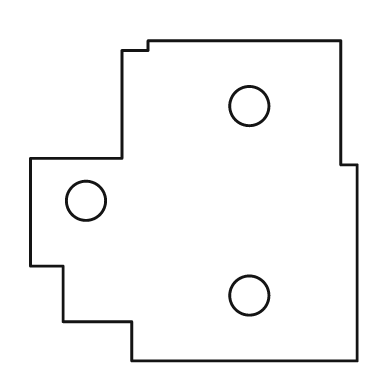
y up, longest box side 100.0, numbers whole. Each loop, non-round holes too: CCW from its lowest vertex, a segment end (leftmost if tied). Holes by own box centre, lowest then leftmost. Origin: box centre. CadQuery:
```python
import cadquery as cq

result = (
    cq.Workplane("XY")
    .moveTo(-19.0, -49.0)
    .lineTo(50.0, -49.0)
    .lineTo(50.0, 11.0)
    .lineTo(45.0, 11.0)
    .lineTo(45.0, 49.0)
    .lineTo(-14.0, 49.0)
    .lineTo(-14.0, 46.0)
    .lineTo(-22.0, 46.0)
    .lineTo(-22.0, 13.0)
    .lineTo(-50.0, 13.0)
    .lineTo(-50.0, -20.0)
    .lineTo(-40.0, -20.0)
    .lineTo(-40.0, -37.0)
    .lineTo(-19.0, -37.0)
    .close()
    .moveTo(17.0, -29.0)
    .circle(6.0)
    .moveTo(-33.0, 0.0)
    .circle(6.0)
    .moveTo(17.0, 29.0)
    .circle(6.0)
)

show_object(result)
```